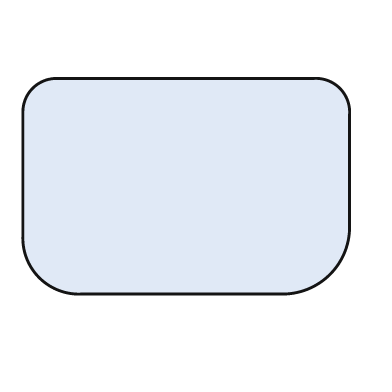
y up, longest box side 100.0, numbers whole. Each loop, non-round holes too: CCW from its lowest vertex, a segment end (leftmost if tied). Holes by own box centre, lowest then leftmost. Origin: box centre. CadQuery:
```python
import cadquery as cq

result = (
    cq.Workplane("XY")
    .moveTo(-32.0, -33.0)
    .lineTo(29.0, -33.0)
    .threePointArc((44.0, -27.0), (50.0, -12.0))
    .lineTo(50.0, 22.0)
    .threePointArc((47.0, 30.0), (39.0, 33.0))
    .lineTo(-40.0, 33.0)
    .threePointArc((-47.0, 30.0), (-50.0, 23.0))
    .lineTo(-50.0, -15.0)
    .threePointArc((-45.0, -28.0), (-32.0, -33.0))
    .close()
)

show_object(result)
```